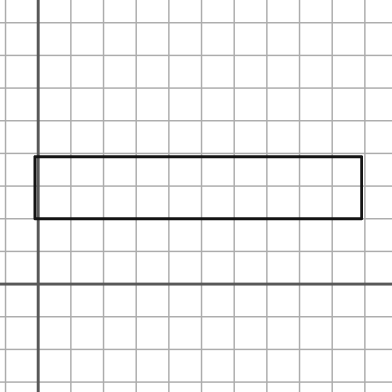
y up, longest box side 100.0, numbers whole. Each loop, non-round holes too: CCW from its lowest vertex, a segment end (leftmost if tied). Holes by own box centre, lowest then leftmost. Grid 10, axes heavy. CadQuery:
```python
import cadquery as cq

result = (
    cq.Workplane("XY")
    .moveTo(-1.0, 20.0)
    .lineTo(99.0, 20.0)
    .lineTo(99.0, 39.0)
    .lineTo(-1.0, 39.0)
    .close()
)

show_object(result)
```